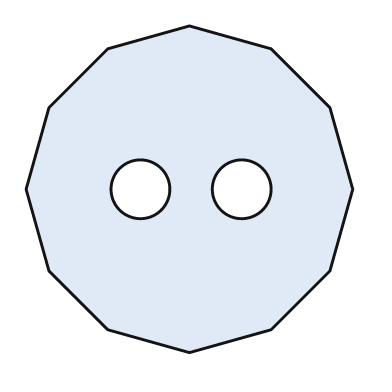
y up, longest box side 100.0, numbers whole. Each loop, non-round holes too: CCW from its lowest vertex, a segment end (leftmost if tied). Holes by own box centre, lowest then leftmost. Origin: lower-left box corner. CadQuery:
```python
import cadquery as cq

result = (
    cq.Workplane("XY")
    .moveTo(50.0, 0.0)
    .lineTo(75.0, 7.0)
    .lineTo(93.0, 25.0)
    .lineTo(100.0, 50.0)
    .lineTo(93.0, 75.0)
    .lineTo(75.0, 93.0)
    .lineTo(50.0, 100.0)
    .lineTo(25.0, 93.0)
    .lineTo(7.0, 75.0)
    .lineTo(0.0, 50.0)
    .lineTo(7.0, 25.0)
    .lineTo(25.0, 7.0)
    .close()
    .moveTo(35.0, 50.0)
    .circle(9.0)
    .moveTo(66.0, 50.0)
    .circle(9.0)
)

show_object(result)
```